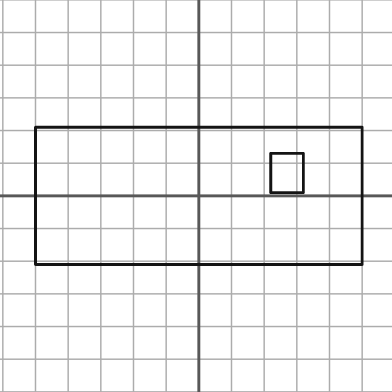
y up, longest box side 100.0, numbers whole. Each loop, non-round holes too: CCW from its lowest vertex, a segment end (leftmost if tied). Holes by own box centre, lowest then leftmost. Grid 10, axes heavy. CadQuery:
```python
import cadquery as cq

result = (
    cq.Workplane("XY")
    .moveTo(-50.0, -21.0)
    .lineTo(50.0, -21.0)
    .lineTo(50.0, 21.0)
    .lineTo(-50.0, 21.0)
    .close()
    .moveTo(22.0, 1.0)
    .lineTo(32.0, 1.0)
    .lineTo(32.0, 13.0)
    .lineTo(22.0, 13.0)
    .close()
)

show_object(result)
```